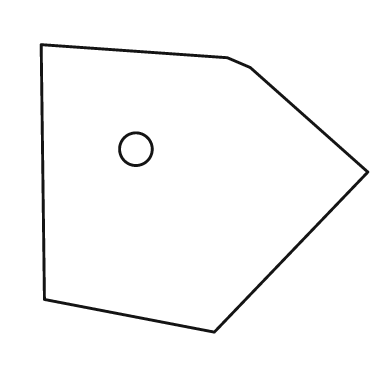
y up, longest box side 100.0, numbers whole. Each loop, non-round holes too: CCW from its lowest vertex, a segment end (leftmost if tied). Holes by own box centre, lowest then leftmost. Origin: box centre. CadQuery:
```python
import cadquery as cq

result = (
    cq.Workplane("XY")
    .moveTo(3.0, -44.0)
    .lineTo(50.0, 5.0)
    .lineTo(14.0, 37.0)
    .lineTo(7.0, 40.0)
    .lineTo(-50.0, 44.0)
    .lineTo(-49.0, -34.0)
    .close()
    .moveTo(-21.0, 12.0)
    .circle(5.0)
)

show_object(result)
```